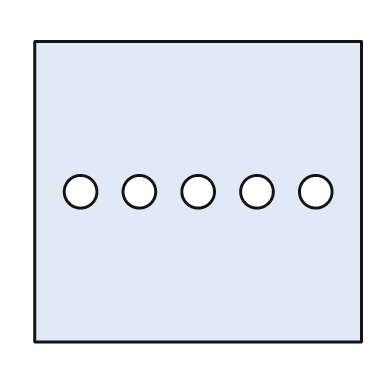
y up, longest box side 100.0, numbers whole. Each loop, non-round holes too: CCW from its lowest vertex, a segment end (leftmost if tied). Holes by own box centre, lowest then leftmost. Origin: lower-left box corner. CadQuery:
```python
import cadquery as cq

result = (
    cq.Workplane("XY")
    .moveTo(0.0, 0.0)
    .lineTo(100.0, 0.0)
    .lineTo(100.0, 92.0)
    .lineTo(0.0, 92.0)
    .close()
    .moveTo(14.0, 46.0)
    .circle(5.0)
    .moveTo(32.0, 46.0)
    .circle(5.0)
    .moveTo(50.0, 46.0)
    .circle(5.0)
    .moveTo(68.0, 46.0)
    .circle(5.0)
    .moveTo(86.0, 46.0)
    .circle(5.0)
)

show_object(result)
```